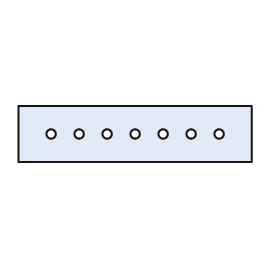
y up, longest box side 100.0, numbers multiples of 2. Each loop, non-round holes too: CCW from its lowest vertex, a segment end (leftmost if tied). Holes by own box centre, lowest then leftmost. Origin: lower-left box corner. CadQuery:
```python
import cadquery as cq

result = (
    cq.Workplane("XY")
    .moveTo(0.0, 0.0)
    .lineTo(100.0, 0.0)
    .lineTo(100.0, 24.0)
    .lineTo(0.0, 24.0)
    .close()
    .moveTo(14.0, 12.0)
    .circle(2.0)
    .moveTo(26.0, 12.0)
    .circle(2.0)
    .moveTo(38.0, 12.0)
    .circle(2.0)
    .moveTo(50.0, 12.0)
    .circle(2.0)
    .moveTo(62.0, 12.0)
    .circle(2.0)
    .moveTo(74.0, 12.0)
    .circle(2.0)
    .moveTo(86.0, 12.0)
    .circle(2.0)
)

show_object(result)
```